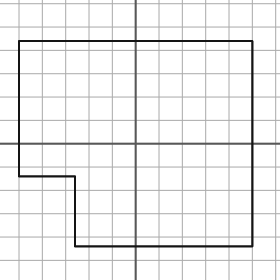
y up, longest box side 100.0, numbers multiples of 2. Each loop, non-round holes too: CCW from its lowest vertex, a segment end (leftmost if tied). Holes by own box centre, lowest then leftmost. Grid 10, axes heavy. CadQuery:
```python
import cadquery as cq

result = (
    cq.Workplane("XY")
    .moveTo(-26.0, -44.0)
    .lineTo(50.0, -44.0)
    .lineTo(50.0, 44.0)
    .lineTo(-50.0, 44.0)
    .lineTo(-50.0, -14.0)
    .lineTo(-26.0, -14.0)
    .close()
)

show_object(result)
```